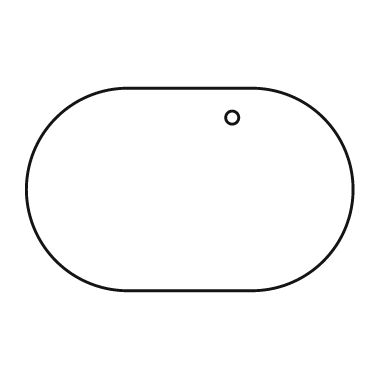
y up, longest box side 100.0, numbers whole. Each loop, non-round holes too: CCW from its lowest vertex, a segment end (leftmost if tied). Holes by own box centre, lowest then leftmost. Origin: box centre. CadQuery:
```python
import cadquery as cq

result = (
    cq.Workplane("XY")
    .moveTo(-19.0, -31.0)
    .lineTo(19.0, -31.0)
    .threePointArc((50.0, 0.0), (19.0, 31.0))
    .lineTo(-19.0, 31.0)
    .threePointArc((-50.0, 0.0), (-19.0, -31.0))
    .close()
    .moveTo(13.0, 22.0)
    .circle(2.0)
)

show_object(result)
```